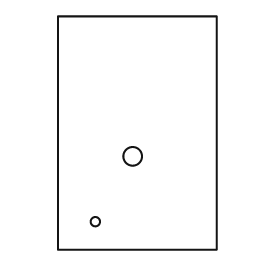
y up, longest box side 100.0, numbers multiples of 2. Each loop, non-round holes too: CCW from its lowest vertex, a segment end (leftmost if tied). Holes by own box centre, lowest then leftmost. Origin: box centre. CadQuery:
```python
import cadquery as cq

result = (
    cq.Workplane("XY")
    .moveTo(-34.0, -50.0)
    .lineTo(34.0, -50.0)
    .lineTo(34.0, 50.0)
    .lineTo(-34.0, 50.0)
    .close()
    .moveTo(-18.0, -38.0)
    .circle(2.0)
    .moveTo(-2.0, -10.0)
    .circle(4.0)
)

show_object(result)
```